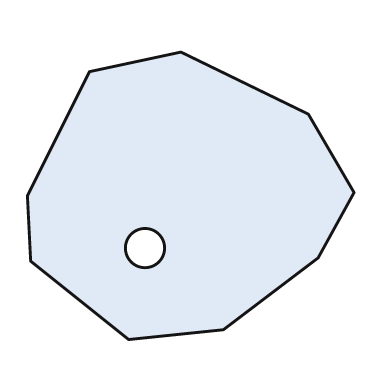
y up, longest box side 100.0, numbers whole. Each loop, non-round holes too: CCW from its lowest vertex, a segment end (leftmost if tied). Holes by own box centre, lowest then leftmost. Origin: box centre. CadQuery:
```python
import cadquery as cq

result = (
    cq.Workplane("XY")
    .moveTo(-19.0, -44.0)
    .lineTo(10.0, -41.0)
    .lineTo(39.0, -19.0)
    .lineTo(50.0, 1.0)
    .lineTo(36.0, 25.0)
    .lineTo(-3.0, 44.0)
    .lineTo(-31.0, 38.0)
    .lineTo(-50.0, 0.0)
    .lineTo(-49.0, -20.0)
    .close()
    .moveTo(-14.0, -16.0)
    .circle(6.0)
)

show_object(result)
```